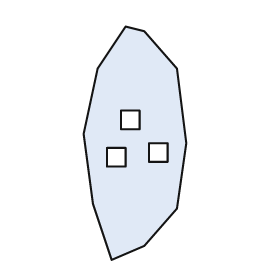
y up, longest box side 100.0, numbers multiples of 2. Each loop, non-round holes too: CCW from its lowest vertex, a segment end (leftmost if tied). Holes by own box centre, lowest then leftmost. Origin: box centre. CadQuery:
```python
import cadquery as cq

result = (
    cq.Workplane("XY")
    .moveTo(-10.0, -50.0)
    .lineTo(4.0, -44.0)
    .lineTo(18.0, -28.0)
    .lineTo(22.0, 0.0)
    .lineTo(18.0, 32.0)
    .lineTo(4.0, 48.0)
    .lineTo(-4.0, 50.0)
    .lineTo(-16.0, 32.0)
    .lineTo(-22.0, 4.0)
    .lineTo(-18.0, -26.0)
    .close()
    .moveTo(-12.0, -10.0)
    .lineTo(-4.0, -10.0)
    .lineTo(-4.0, -2.0)
    .lineTo(-12.0, -2.0)
    .close()
    .moveTo(6.0, -8.0)
    .lineTo(14.0, -8.0)
    .lineTo(14.0, 0.0)
    .lineTo(6.0, 0.0)
    .close()
    .moveTo(-6.0, 6.0)
    .lineTo(2.0, 6.0)
    .lineTo(2.0, 14.0)
    .lineTo(-6.0, 14.0)
    .close()
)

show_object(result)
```